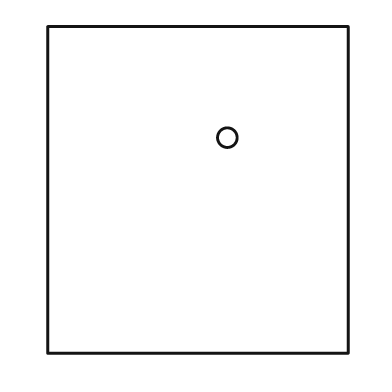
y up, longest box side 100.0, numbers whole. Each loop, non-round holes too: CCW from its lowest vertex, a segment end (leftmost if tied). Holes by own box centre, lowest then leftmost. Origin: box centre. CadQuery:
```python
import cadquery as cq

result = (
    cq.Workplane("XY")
    .moveTo(-46.0, -50.0)
    .lineTo(46.0, -50.0)
    .lineTo(46.0, 50.0)
    .lineTo(-46.0, 50.0)
    .close()
    .moveTo(9.0, 16.0)
    .circle(3.0)
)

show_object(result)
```